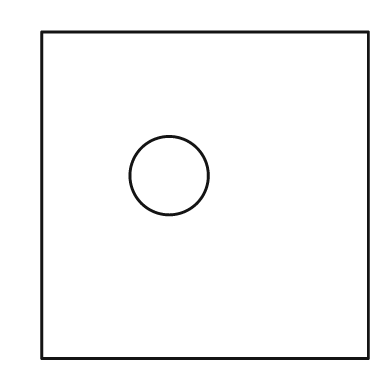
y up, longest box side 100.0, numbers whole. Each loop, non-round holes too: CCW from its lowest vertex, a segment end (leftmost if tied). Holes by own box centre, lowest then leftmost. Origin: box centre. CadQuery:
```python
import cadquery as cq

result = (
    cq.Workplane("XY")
    .moveTo(-50.0, -50.0)
    .lineTo(50.0, -50.0)
    .lineTo(50.0, 50.0)
    .lineTo(-50.0, 50.0)
    .close()
    .moveTo(-11.0, 6.0)
    .circle(12.0)
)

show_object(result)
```